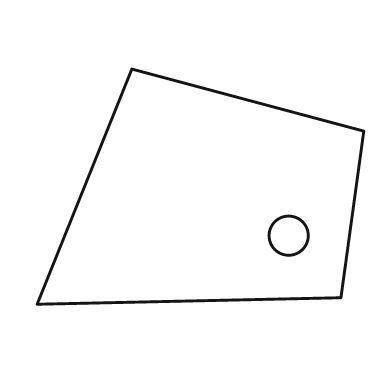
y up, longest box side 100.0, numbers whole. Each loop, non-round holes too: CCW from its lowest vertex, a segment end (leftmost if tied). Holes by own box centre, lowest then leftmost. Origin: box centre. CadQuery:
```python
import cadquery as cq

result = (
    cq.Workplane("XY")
    .moveTo(-50.0, -36.0)
    .lineTo(43.0, -34.0)
    .lineTo(50.0, 17.0)
    .lineTo(-21.0, 36.0)
    .close()
    .moveTo(27.0, -15.0)
    .circle(6.0)
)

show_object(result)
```